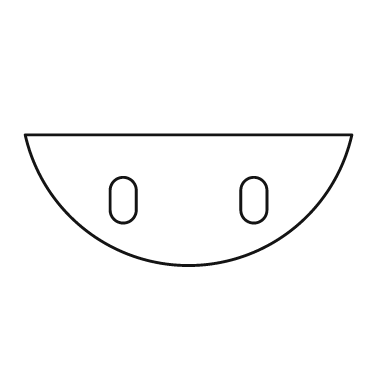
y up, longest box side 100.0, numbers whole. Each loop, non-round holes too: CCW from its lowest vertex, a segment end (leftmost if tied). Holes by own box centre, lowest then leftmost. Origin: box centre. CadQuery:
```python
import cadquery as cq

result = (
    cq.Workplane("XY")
    .moveTo(-50.0, 20.0)
    .threePointArc((0.0, -20.0), (50.0, 20.0))
    .close()
    .moveTo(-24.0, -3.0)
    .threePointArc((-20.0, -7.0), (-16.0, -3.0))
    .lineTo(-16.0, 3.0)
    .threePointArc((-20.0, 7.0), (-24.0, 3.0))
    .close()
    .moveTo(16.0, -3.0)
    .threePointArc((20.0, -7.0), (24.0, -3.0))
    .lineTo(24.0, 3.0)
    .threePointArc((20.0, 7.0), (16.0, 3.0))
    .close()
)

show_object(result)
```